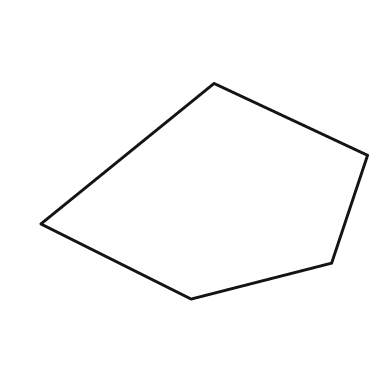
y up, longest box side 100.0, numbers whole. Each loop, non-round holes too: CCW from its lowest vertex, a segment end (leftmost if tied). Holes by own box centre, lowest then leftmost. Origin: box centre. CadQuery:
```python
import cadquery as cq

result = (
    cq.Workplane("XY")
    .moveTo(-4.0, -33.0)
    .lineTo(39.0, -22.0)
    .lineTo(50.0, 11.0)
    .lineTo(3.0, 33.0)
    .lineTo(-50.0, -10.0)
    .close()
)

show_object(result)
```